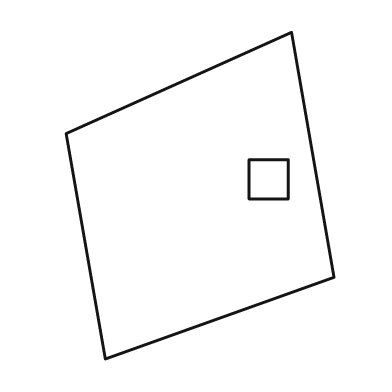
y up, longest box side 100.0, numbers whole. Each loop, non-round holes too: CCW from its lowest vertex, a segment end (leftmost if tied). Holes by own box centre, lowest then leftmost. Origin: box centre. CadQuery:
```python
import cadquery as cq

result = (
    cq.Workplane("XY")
    .moveTo(-29.0, -50.0)
    .lineTo(41.0, -25.0)
    .lineTo(28.0, 50.0)
    .lineTo(-41.0, 19.0)
    .close()
    .moveTo(15.0, -1.0)
    .lineTo(27.0, -1.0)
    .lineTo(27.0, 11.0)
    .lineTo(15.0, 11.0)
    .close()
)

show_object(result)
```